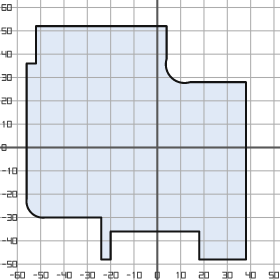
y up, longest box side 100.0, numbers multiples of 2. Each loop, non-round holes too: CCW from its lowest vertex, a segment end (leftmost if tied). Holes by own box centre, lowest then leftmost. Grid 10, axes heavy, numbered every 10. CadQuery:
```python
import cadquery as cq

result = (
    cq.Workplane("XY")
    .moveTo(-24.0, -48.0)
    .lineTo(-20.0, -48.0)
    .lineTo(-20.0, -36.0)
    .lineTo(18.0, -36.0)
    .lineTo(18.0, -48.0)
    .lineTo(38.0, -48.0)
    .lineTo(38.0, 28.0)
    .lineTo(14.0, 28.0)
    .threePointArc((6.0, 30.0), (4.0, 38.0))
    .lineTo(4.0, 52.0)
    .lineTo(-52.0, 52.0)
    .lineTo(-52.0, 36.0)
    .lineTo(-56.0, 36.0)
    .lineTo(-56.0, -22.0)
    .threePointArc((-54.0, -28.0), (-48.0, -30.0))
    .lineTo(-24.0, -30.0)
    .close()
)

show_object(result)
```